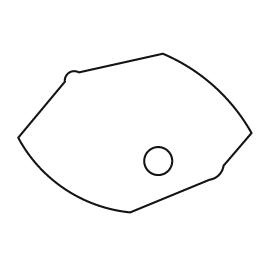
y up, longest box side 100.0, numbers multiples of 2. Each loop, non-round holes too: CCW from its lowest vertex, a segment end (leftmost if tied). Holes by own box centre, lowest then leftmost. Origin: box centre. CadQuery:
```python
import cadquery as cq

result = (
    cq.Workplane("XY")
    .moveTo(-2.0, -34.0)
    .lineTo(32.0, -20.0)
    .threePointArc((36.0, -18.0), (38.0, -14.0))
    .lineTo(50.0, 0.0)
    .threePointArc((34.0, 20.0), (12.0, 34.0))
    .lineTo(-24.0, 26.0)
    .threePointArc((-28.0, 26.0), (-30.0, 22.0))
    .lineTo(-50.0, -2.0)
    .threePointArc((-30.0, -24.0), (-2.0, -34.0))
    .close()
    .moveTo(10.0, -12.0)
    .circle(6.0)
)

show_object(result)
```